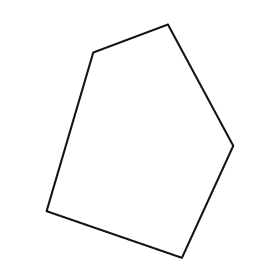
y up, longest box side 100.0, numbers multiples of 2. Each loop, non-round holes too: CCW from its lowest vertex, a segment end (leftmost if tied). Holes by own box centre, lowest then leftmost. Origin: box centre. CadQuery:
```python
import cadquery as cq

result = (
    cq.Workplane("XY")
    .moveTo(18.0, -50.0)
    .lineTo(40.0, -2.0)
    .lineTo(12.0, 50.0)
    .lineTo(-20.0, 38.0)
    .lineTo(-40.0, -30.0)
    .close()
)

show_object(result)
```